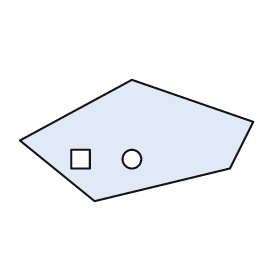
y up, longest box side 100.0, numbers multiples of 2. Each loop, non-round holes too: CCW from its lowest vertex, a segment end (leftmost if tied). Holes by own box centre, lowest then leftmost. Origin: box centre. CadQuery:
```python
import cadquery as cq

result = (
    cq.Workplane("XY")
    .moveTo(-18.0, -26.0)
    .lineTo(40.0, -12.0)
    .lineTo(50.0, 8.0)
    .lineTo(-2.0, 26.0)
    .lineTo(-50.0, 0.0)
    .close()
    .moveTo(-28.0, -12.0)
    .lineTo(-20.0, -12.0)
    .lineTo(-20.0, -4.0)
    .lineTo(-28.0, -4.0)
    .close()
    .moveTo(-2.0, -8.0)
    .circle(4.0)
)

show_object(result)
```